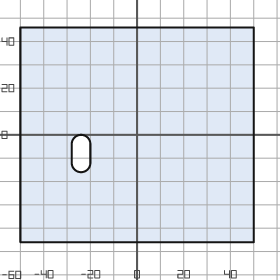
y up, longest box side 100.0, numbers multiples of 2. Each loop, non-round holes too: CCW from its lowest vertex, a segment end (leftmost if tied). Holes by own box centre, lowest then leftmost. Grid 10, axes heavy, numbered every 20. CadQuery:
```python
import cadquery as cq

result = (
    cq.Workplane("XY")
    .moveTo(-50.0, -46.0)
    .lineTo(50.0, -46.0)
    .lineTo(50.0, 46.0)
    .lineTo(-50.0, 46.0)
    .close()
    .moveTo(-28.0, -12.0)
    .threePointArc((-24.0, -16.0), (-20.0, -12.0))
    .lineTo(-20.0, -4.0)
    .threePointArc((-24.0, 0.0), (-28.0, -4.0))
    .close()
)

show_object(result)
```